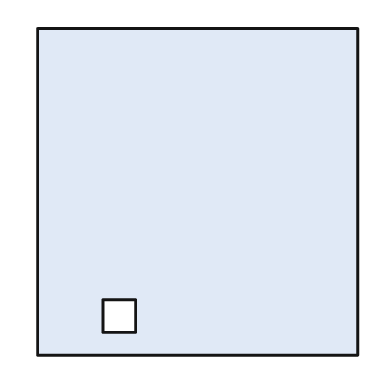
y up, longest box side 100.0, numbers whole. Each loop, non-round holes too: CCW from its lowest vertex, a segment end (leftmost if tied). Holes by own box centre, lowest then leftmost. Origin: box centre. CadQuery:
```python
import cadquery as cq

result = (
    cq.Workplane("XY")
    .moveTo(-49.0, -50.0)
    .lineTo(49.0, -50.0)
    .lineTo(49.0, 50.0)
    .lineTo(-49.0, 50.0)
    .close()
    .moveTo(-29.0, -43.0)
    .lineTo(-19.0, -43.0)
    .lineTo(-19.0, -33.0)
    .lineTo(-29.0, -33.0)
    .close()
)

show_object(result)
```